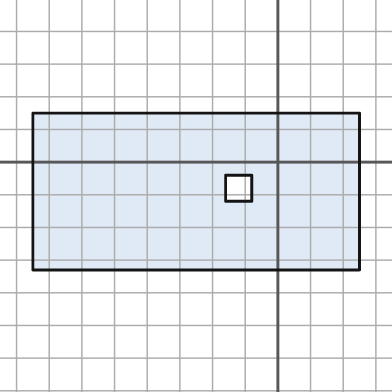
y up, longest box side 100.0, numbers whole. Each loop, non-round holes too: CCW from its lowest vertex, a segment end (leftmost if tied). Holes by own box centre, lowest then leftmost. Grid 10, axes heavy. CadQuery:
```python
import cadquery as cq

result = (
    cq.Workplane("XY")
    .moveTo(-75.0, -33.0)
    .lineTo(25.0, -33.0)
    .lineTo(25.0, 15.0)
    .lineTo(-75.0, 15.0)
    .close()
    .moveTo(-16.0, -12.0)
    .lineTo(-8.0, -12.0)
    .lineTo(-8.0, -4.0)
    .lineTo(-16.0, -4.0)
    .close()
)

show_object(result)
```